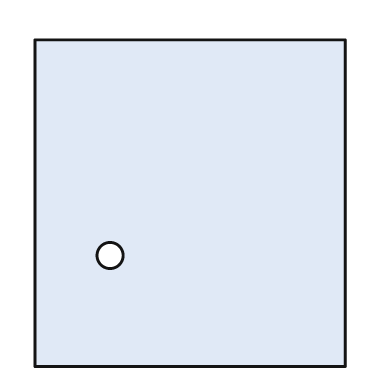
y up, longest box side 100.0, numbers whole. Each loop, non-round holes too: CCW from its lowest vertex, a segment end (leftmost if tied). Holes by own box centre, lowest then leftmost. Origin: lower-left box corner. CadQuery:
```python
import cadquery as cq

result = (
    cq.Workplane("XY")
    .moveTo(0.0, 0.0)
    .lineTo(95.0, 0.0)
    .lineTo(95.0, 100.0)
    .lineTo(0.0, 100.0)
    .close()
    .moveTo(23.0, 34.0)
    .circle(4.0)
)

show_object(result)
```